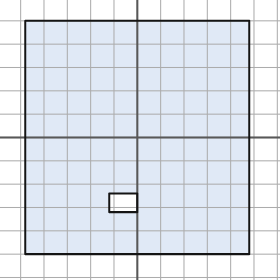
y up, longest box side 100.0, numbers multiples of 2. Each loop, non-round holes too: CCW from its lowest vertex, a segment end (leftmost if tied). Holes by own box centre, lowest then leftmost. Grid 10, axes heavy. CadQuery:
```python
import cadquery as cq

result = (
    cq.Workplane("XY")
    .moveTo(-48.0, -50.0)
    .lineTo(48.0, -50.0)
    .lineTo(48.0, 50.0)
    .lineTo(-48.0, 50.0)
    .close()
    .moveTo(-12.0, -32.0)
    .lineTo(0.0, -32.0)
    .lineTo(0.0, -24.0)
    .lineTo(-12.0, -24.0)
    .close()
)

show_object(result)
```